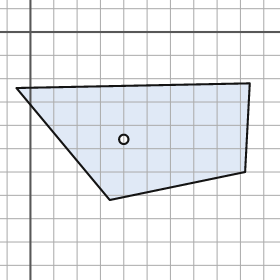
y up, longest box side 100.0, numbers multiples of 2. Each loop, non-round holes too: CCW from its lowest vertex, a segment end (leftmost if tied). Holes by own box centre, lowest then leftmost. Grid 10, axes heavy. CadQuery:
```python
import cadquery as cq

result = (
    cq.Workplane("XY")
    .moveTo(34.0, -72.0)
    .lineTo(92.0, -60.0)
    .lineTo(94.0, -22.0)
    .lineTo(-6.0, -24.0)
    .close()
    .moveTo(40.0, -46.0)
    .circle(2.0)
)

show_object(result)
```